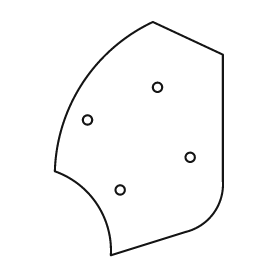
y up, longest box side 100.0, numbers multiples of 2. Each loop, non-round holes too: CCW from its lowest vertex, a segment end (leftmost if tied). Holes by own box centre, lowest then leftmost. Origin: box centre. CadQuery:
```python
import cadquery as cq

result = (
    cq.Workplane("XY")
    .moveTo(-12.0, -50.0)
    .lineTo(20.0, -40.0)
    .threePointArc((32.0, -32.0), (36.0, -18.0))
    .lineTo(36.0, 36.0)
    .lineTo(6.0, 50.0)
    .threePointArc((-24.0, 24.0), (-36.0, -14.0))
    .threePointArc((-18.0, -28.0), (-12.0, -50.0))
    .close()
    .moveTo(-8.0, -22.0)
    .circle(2.0)
    .moveTo(22.0, -8.0)
    .circle(2.0)
    .moveTo(-22.0, 8.0)
    .circle(2.0)
    .moveTo(8.0, 22.0)
    .circle(2.0)
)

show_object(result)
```